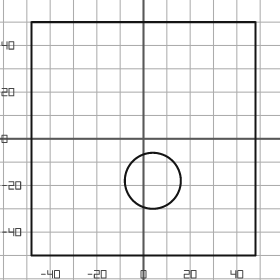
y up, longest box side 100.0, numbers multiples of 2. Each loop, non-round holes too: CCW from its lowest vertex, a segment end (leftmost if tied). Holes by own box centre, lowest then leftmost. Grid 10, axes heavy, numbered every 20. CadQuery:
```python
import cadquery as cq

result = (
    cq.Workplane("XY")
    .moveTo(-48.0, -50.0)
    .lineTo(48.0, -50.0)
    .lineTo(48.0, 50.0)
    .lineTo(-48.0, 50.0)
    .close()
    .moveTo(4.0, -18.0)
    .circle(12.0)
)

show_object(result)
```